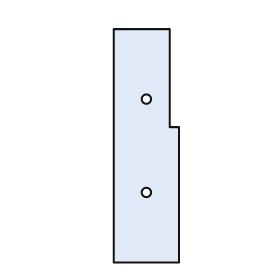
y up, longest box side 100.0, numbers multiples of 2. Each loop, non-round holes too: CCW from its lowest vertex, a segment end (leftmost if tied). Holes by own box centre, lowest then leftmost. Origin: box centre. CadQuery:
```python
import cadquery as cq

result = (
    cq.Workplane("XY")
    .moveTo(-14.0, -50.0)
    .lineTo(14.0, -50.0)
    .lineTo(14.0, 8.0)
    .lineTo(10.0, 8.0)
    .lineTo(10.0, 50.0)
    .lineTo(-14.0, 50.0)
    .close()
    .moveTo(0.0, -20.0)
    .circle(2.0)
    .moveTo(0.0, 20.0)
    .circle(2.0)
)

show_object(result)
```